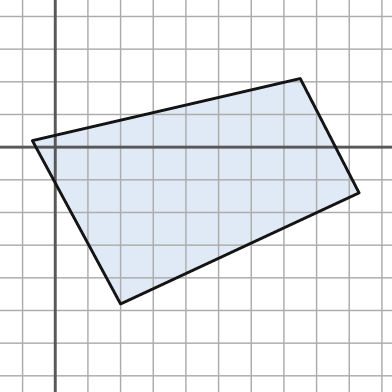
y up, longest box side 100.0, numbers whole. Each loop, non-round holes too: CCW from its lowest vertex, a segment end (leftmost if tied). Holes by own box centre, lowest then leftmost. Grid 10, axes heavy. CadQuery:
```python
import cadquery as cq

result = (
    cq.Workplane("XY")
    .moveTo(20.0, -48.0)
    .lineTo(93.0, -14.0)
    .lineTo(75.0, 21.0)
    .lineTo(-7.0, 2.0)
    .close()
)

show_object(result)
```